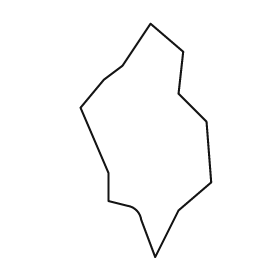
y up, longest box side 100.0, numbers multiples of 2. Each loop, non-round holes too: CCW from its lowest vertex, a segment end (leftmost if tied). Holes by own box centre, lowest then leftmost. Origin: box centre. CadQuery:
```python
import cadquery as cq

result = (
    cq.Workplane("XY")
    .moveTo(4.0, -50.0)
    .lineTo(14.0, -30.0)
    .lineTo(28.0, -18.0)
    .lineTo(26.0, 8.0)
    .lineTo(14.0, 20.0)
    .lineTo(16.0, 38.0)
    .lineTo(2.0, 50.0)
    .lineTo(-10.0, 32.0)
    .lineTo(-18.0, 26.0)
    .lineTo(-28.0, 14.0)
    .lineTo(-16.0, -14.0)
    .lineTo(-16.0, -26.0)
    .lineTo(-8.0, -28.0)
    .threePointArc((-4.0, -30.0), (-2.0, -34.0))
    .close()
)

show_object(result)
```